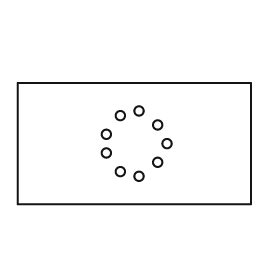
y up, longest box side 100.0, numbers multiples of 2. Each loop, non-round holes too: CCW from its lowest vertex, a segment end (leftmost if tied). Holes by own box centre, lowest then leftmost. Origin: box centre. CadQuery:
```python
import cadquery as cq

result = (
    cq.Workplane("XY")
    .moveTo(-50.0, -26.0)
    .lineTo(50.0, -26.0)
    .lineTo(50.0, 26.0)
    .lineTo(-50.0, 26.0)
    .close()
    .moveTo(2.0, -14.0)
    .circle(2.0)
    .moveTo(-6.0, -12.0)
    .circle(2.0)
    .moveTo(10.0, -8.0)
    .circle(2.0)
    .moveTo(-12.0, -4.0)
    .circle(2.0)
    .moveTo(14.0, 0.0)
    .circle(2.0)
    .moveTo(-12.0, 4.0)
    .circle(2.0)
    .moveTo(10.0, 8.0)
    .circle(2.0)
    .moveTo(-6.0, 12.0)
    .circle(2.0)
    .moveTo(2.0, 14.0)
    .circle(2.0)
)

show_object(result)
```